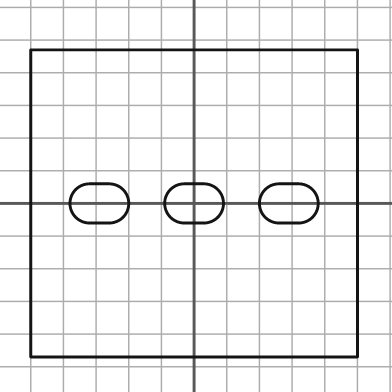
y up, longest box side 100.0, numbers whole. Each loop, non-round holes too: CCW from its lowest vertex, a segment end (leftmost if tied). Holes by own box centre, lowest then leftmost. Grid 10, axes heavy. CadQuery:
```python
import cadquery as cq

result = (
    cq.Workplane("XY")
    .moveTo(-50.0, -47.0)
    .lineTo(50.0, -47.0)
    .lineTo(50.0, 47.0)
    .lineTo(-50.0, 47.0)
    .close()
    .moveTo(-32.0, -6.0)
    .lineTo(-26.0, -6.0)
    .threePointArc((-20.0, 0.0), (-26.0, 6.0))
    .lineTo(-32.0, 6.0)
    .threePointArc((-38.0, 0.0), (-32.0, -6.0))
    .close()
    .moveTo(-3.0, -6.0)
    .lineTo(3.0, -6.0)
    .threePointArc((9.0, 0.0), (3.0, 6.0))
    .lineTo(-3.0, 6.0)
    .threePointArc((-9.0, 0.0), (-3.0, -6.0))
    .close()
    .moveTo(26.0, -6.0)
    .lineTo(32.0, -6.0)
    .threePointArc((38.0, 0.0), (32.0, 6.0))
    .lineTo(26.0, 6.0)
    .threePointArc((20.0, 0.0), (26.0, -6.0))
    .close()
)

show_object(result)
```